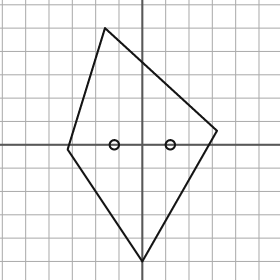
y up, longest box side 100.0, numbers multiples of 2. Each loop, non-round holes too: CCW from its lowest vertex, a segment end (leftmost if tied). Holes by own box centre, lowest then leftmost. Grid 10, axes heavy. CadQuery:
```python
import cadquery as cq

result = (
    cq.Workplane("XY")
    .moveTo(0.0, -50.0)
    .lineTo(32.0, 6.0)
    .lineTo(-16.0, 50.0)
    .lineTo(-32.0, -2.0)
    .close()
    .moveTo(-12.0, 0.0)
    .circle(2.0)
    .moveTo(12.0, 0.0)
    .circle(2.0)
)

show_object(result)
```